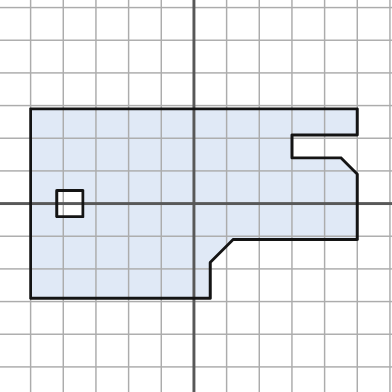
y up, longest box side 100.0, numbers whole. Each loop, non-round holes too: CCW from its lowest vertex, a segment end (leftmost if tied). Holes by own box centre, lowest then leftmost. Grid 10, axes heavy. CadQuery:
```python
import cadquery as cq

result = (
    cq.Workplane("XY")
    .moveTo(-50.0, -29.0)
    .lineTo(5.0, -29.0)
    .lineTo(5.0, -18.0)
    .lineTo(12.0, -11.0)
    .lineTo(50.0, -11.0)
    .lineTo(50.0, 9.0)
    .lineTo(45.0, 14.0)
    .lineTo(30.0, 14.0)
    .lineTo(30.0, 21.0)
    .lineTo(50.0, 21.0)
    .lineTo(50.0, 29.0)
    .lineTo(-50.0, 29.0)
    .close()
    .moveTo(-42.0, -4.0)
    .lineTo(-34.0, -4.0)
    .lineTo(-34.0, 4.0)
    .lineTo(-42.0, 4.0)
    .close()
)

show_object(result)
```